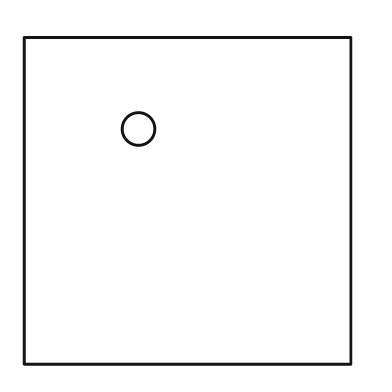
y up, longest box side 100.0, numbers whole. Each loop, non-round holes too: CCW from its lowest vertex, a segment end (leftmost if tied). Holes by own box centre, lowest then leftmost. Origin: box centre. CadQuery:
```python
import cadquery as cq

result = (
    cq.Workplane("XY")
    .moveTo(-50.0, -50.0)
    .lineTo(50.0, -50.0)
    .lineTo(50.0, 50.0)
    .lineTo(-50.0, 50.0)
    .close()
    .moveTo(-15.0, 22.0)
    .circle(5.0)
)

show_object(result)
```